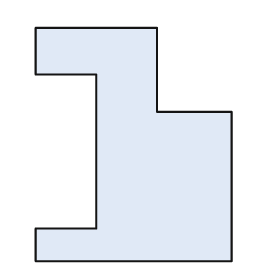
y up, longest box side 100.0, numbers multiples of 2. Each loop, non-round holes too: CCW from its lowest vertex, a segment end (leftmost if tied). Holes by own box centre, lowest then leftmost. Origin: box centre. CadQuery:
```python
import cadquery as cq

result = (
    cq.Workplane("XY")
    .moveTo(-42.0, -50.0)
    .lineTo(42.0, -50.0)
    .lineTo(42.0, 14.0)
    .lineTo(10.0, 14.0)
    .lineTo(10.0, 50.0)
    .lineTo(-42.0, 50.0)
    .lineTo(-42.0, 30.0)
    .lineTo(-16.0, 30.0)
    .lineTo(-16.0, -36.0)
    .lineTo(-42.0, -36.0)
    .close()
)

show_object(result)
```